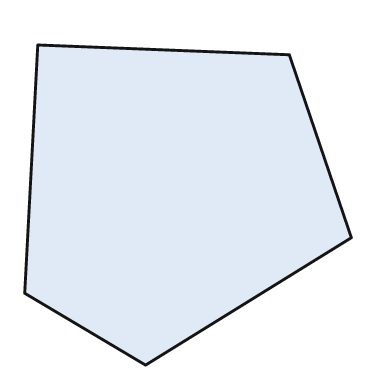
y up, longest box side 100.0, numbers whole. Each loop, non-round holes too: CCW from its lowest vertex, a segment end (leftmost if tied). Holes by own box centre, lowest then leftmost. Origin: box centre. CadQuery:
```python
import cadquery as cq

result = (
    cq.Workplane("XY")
    .moveTo(-13.0, -49.0)
    .lineTo(50.0, -10.0)
    .lineTo(31.0, 46.0)
    .lineTo(-46.0, 49.0)
    .lineTo(-50.0, -27.0)
    .close()
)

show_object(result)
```